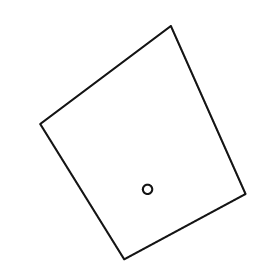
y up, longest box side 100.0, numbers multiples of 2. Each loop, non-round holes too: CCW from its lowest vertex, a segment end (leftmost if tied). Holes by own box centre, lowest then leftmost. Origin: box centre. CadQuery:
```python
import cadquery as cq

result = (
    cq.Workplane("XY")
    .moveTo(-8.0, -50.0)
    .lineTo(44.0, -22.0)
    .lineTo(12.0, 50.0)
    .lineTo(-44.0, 8.0)
    .close()
    .moveTo(2.0, -20.0)
    .circle(2.0)
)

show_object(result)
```